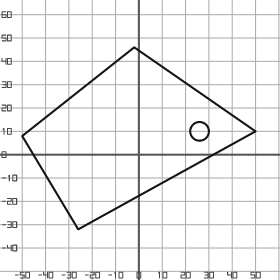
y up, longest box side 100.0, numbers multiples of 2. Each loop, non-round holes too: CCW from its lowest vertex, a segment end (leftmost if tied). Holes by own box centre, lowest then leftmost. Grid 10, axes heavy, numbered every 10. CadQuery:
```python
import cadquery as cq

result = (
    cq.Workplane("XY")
    .moveTo(-26.0, -32.0)
    .lineTo(50.0, 10.0)
    .lineTo(-2.0, 46.0)
    .lineTo(-50.0, 8.0)
    .close()
    .moveTo(26.0, 10.0)
    .circle(4.0)
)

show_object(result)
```